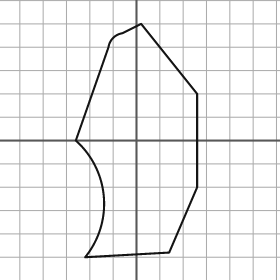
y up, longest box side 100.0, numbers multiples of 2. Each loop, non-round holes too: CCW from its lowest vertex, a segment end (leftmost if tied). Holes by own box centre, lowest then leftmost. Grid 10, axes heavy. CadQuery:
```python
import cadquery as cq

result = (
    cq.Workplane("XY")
    .moveTo(-22.0, -50.0)
    .lineTo(14.0, -48.0)
    .lineTo(26.0, -20.0)
    .lineTo(26.0, 20.0)
    .lineTo(2.0, 50.0)
    .lineTo(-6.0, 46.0)
    .threePointArc((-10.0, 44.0), (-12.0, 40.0))
    .lineTo(-26.0, 0.0)
    .threePointArc((-14.0, -24.0), (-22.0, -50.0))
    .close()
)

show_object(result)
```